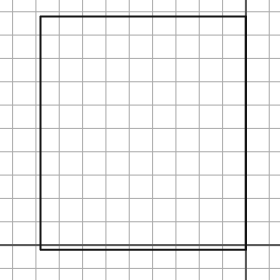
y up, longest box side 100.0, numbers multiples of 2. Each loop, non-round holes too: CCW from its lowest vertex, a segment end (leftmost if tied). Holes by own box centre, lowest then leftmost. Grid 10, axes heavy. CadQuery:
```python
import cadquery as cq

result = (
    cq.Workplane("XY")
    .moveTo(-88.0, -2.0)
    .lineTo(0.0, -2.0)
    .lineTo(0.0, 98.0)
    .lineTo(-88.0, 98.0)
    .close()
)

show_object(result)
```